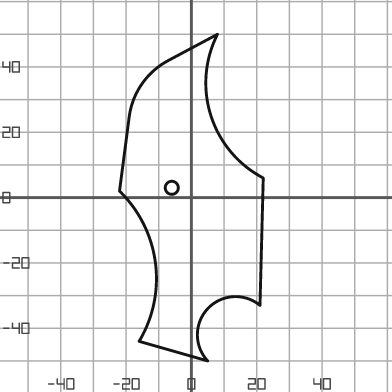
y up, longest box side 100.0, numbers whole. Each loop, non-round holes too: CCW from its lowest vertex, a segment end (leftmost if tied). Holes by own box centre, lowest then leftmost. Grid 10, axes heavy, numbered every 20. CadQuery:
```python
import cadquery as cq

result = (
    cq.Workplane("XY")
    .moveTo(5.0, -50.0)
    .threePointArc((5.0, -34.0), (21.0, -33.0))
    .lineTo(22.0, 6.0)
    .threePointArc((6.0, 25.0), (8.0, 50.0))
    .lineTo(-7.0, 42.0)
    .threePointArc((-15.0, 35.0), (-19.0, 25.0))
    .lineTo(-22.0, 2.0)
    .threePointArc((-11.0, -20.0), (-16.0, -44.0))
    .close()
    .moveTo(-6.0, 3.0)
    .circle(2.0)
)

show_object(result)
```